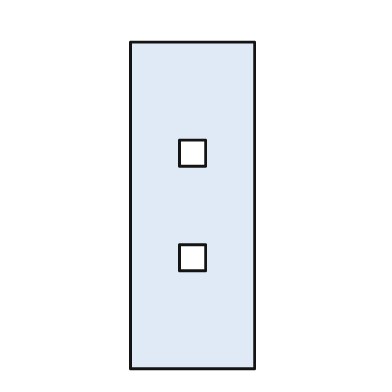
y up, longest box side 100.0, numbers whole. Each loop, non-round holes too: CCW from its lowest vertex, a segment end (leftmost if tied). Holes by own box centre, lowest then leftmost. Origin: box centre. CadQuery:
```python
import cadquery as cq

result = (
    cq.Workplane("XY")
    .moveTo(-19.0, -50.0)
    .lineTo(19.0, -50.0)
    .lineTo(19.0, 50.0)
    .lineTo(-19.0, 50.0)
    .close()
    .moveTo(-4.0, -20.0)
    .lineTo(4.0, -20.0)
    .lineTo(4.0, -12.0)
    .lineTo(-4.0, -12.0)
    .close()
    .moveTo(-4.0, 12.0)
    .lineTo(4.0, 12.0)
    .lineTo(4.0, 20.0)
    .lineTo(-4.0, 20.0)
    .close()
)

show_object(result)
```